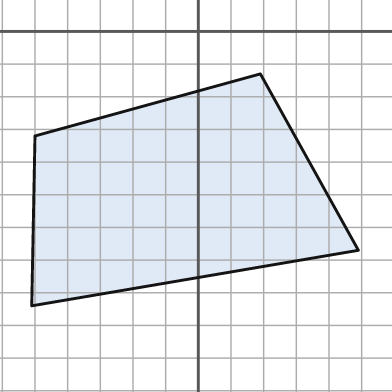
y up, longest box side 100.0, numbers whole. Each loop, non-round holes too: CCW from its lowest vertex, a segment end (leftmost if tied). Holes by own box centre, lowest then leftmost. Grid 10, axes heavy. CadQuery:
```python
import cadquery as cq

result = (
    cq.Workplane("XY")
    .moveTo(-51.0, -84.0)
    .lineTo(49.0, -67.0)
    .lineTo(19.0, -13.0)
    .lineTo(-50.0, -32.0)
    .close()
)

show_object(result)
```